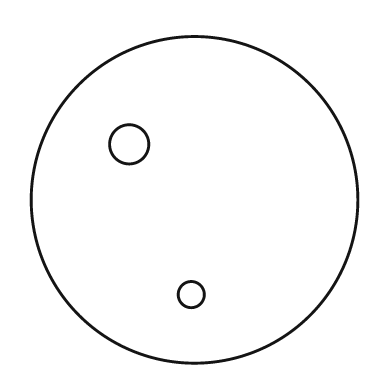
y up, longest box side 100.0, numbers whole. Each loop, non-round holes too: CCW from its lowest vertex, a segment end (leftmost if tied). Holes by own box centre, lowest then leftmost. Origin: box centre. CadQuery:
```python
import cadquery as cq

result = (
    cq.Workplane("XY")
    .moveTo(0.0, 0.0)
    .circle(50.0)
    .moveTo(-1.0, -29.0)
    .circle(4.0)
    .moveTo(-20.0, 17.0)
    .circle(6.0)
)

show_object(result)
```